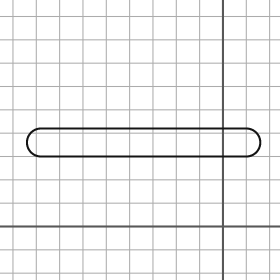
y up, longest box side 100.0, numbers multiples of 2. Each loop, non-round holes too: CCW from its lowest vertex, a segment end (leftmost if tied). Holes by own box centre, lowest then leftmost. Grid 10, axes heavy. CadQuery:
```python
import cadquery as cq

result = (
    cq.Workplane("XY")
    .moveTo(-78.0, 30.0)
    .lineTo(10.0, 30.0)
    .threePointArc((16.0, 36.0), (10.0, 42.0))
    .lineTo(-78.0, 42.0)
    .threePointArc((-84.0, 36.0), (-78.0, 30.0))
    .close()
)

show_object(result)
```